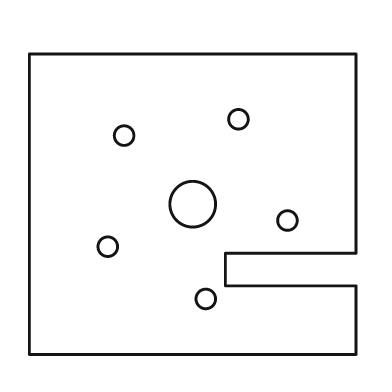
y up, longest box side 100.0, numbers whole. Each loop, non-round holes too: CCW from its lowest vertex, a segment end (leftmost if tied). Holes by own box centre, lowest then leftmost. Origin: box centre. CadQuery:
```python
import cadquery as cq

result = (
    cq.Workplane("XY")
    .moveTo(-50.0, -46.0)
    .lineTo(50.0, -46.0)
    .lineTo(50.0, -25.0)
    .lineTo(10.0, -25.0)
    .lineTo(10.0, -15.0)
    .lineTo(50.0, -15.0)
    .lineTo(50.0, 46.0)
    .lineTo(-50.0, 46.0)
    .close()
    .moveTo(4.0, -29.0)
    .circle(3.0)
    .moveTo(-26.0, -13.0)
    .circle(3.0)
    .moveTo(29.0, -5.0)
    .circle(3.0)
    .moveTo(0.0, 0.0)
    .circle(7.0)
    .moveTo(-21.0, 21.0)
    .circle(3.0)
    .moveTo(14.0, 26.0)
    .circle(3.0)
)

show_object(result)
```